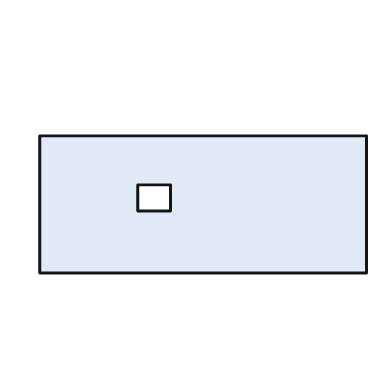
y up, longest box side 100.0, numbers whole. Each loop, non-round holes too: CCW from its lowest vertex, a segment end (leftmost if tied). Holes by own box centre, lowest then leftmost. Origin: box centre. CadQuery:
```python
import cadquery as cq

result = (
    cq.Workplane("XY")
    .moveTo(-50.0, -21.0)
    .lineTo(50.0, -21.0)
    .lineTo(50.0, 21.0)
    .lineTo(-50.0, 21.0)
    .close()
    .moveTo(-20.0, -2.0)
    .lineTo(-10.0, -2.0)
    .lineTo(-10.0, 6.0)
    .lineTo(-20.0, 6.0)
    .close()
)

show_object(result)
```